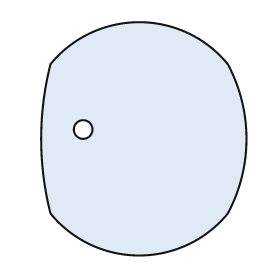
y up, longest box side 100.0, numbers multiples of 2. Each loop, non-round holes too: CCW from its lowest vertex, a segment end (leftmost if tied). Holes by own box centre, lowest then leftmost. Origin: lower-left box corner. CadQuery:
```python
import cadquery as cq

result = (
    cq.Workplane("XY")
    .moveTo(4.0, 18.0)
    .threePointArc((42.0, 0.0), (80.0, 18.0))
    .threePointArc((88.0, 50.0), (80.0, 82.0))
    .threePointArc((42.0, 100.0), (4.0, 82.0))
    .threePointArc((0.0, 50.0), (4.0, 18.0))
    .close()
    .moveTo(18.0, 54.0)
    .circle(4.0)
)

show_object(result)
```